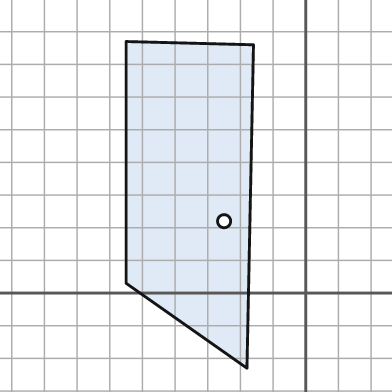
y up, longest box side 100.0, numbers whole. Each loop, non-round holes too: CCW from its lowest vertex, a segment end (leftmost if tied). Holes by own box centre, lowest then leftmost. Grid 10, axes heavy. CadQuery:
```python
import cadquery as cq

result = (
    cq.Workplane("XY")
    .moveTo(-18.0, -23.0)
    .lineTo(-16.0, 76.0)
    .lineTo(-55.0, 77.0)
    .lineTo(-55.0, 3.0)
    .close()
    .moveTo(-25.0, 22.0)
    .circle(2.0)
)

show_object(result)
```